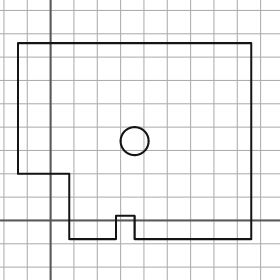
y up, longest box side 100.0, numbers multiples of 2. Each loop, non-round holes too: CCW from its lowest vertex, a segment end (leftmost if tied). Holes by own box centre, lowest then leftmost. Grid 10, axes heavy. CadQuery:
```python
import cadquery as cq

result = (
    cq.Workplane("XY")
    .moveTo(8.0, -8.0)
    .lineTo(28.0, -8.0)
    .lineTo(28.0, 2.0)
    .lineTo(36.0, 2.0)
    .lineTo(36.0, -8.0)
    .lineTo(86.0, -8.0)
    .lineTo(86.0, 76.0)
    .lineTo(-14.0, 76.0)
    .lineTo(-14.0, 20.0)
    .lineTo(8.0, 20.0)
    .close()
    .moveTo(36.0, 34.0)
    .circle(6.0)
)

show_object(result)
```